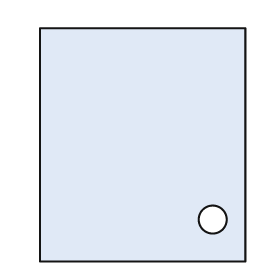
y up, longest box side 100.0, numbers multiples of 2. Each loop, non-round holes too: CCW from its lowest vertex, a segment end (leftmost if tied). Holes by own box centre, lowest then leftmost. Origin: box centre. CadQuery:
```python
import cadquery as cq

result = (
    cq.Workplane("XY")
    .moveTo(-44.0, -50.0)
    .lineTo(44.0, -50.0)
    .lineTo(44.0, 50.0)
    .lineTo(-44.0, 50.0)
    .close()
    .moveTo(30.0, -32.0)
    .circle(6.0)
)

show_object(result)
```